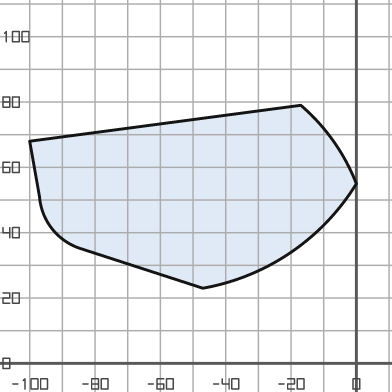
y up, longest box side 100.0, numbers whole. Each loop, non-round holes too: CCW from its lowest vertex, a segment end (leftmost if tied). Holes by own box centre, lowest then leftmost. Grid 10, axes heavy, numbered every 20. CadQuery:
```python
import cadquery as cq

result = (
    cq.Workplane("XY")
    .moveTo(-47.0, 23.0)
    .threePointArc((-20.0, 34.0), (0.0, 55.0))
    .threePointArc((-7.0, 68.0), (-17.0, 79.0))
    .lineTo(-100.0, 68.0)
    .lineTo(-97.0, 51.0)
    .threePointArc((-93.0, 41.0), (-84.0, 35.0))
    .close()
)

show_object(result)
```